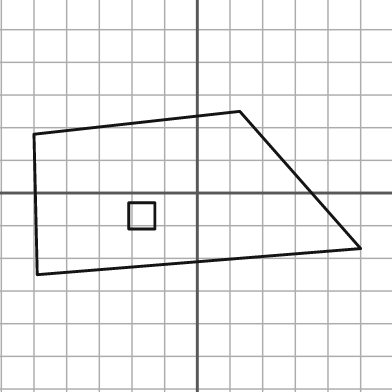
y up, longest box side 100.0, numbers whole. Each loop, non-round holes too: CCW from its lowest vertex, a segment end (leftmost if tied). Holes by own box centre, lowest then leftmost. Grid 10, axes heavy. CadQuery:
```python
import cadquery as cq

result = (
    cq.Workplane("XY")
    .moveTo(-49.0, -25.0)
    .lineTo(50.0, -17.0)
    .lineTo(13.0, 25.0)
    .lineTo(-50.0, 18.0)
    .close()
    .moveTo(-21.0, -11.0)
    .lineTo(-13.0, -11.0)
    .lineTo(-13.0, -3.0)
    .lineTo(-21.0, -3.0)
    .close()
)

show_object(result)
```